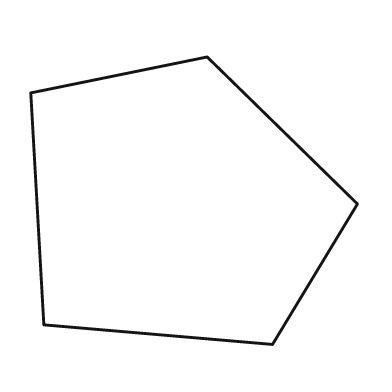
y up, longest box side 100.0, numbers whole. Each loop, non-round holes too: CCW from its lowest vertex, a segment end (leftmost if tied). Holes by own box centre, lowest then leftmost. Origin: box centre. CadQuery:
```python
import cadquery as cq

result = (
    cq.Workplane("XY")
    .moveTo(24.0, -44.0)
    .lineTo(50.0, -1.0)
    .lineTo(4.0, 44.0)
    .lineTo(-50.0, 33.0)
    .lineTo(-46.0, -38.0)
    .close()
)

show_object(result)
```